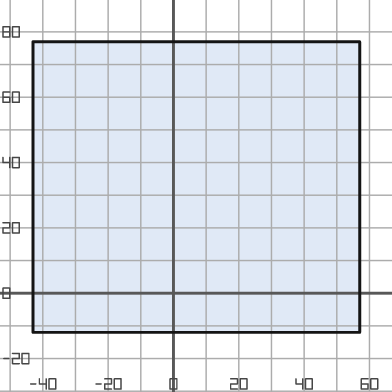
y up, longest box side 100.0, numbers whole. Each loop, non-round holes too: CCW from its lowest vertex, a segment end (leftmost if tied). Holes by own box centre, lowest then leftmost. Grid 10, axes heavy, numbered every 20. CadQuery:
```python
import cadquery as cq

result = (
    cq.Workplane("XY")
    .moveTo(-43.0, -12.0)
    .lineTo(57.0, -12.0)
    .lineTo(57.0, 77.0)
    .lineTo(-43.0, 77.0)
    .close()
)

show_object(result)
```